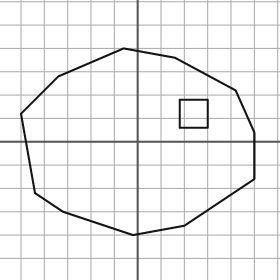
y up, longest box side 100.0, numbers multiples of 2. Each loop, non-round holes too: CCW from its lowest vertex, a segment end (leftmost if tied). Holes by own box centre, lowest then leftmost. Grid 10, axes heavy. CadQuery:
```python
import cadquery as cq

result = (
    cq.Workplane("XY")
    .moveTo(-2.0, -40.0)
    .lineTo(20.0, -36.0)
    .lineTo(50.0, -16.0)
    .lineTo(50.0, 4.0)
    .lineTo(42.0, 22.0)
    .lineTo(16.0, 36.0)
    .lineTo(-6.0, 40.0)
    .lineTo(-34.0, 28.0)
    .lineTo(-50.0, 12.0)
    .lineTo(-44.0, -22.0)
    .lineTo(-32.0, -30.0)
    .close()
    .moveTo(18.0, 6.0)
    .lineTo(30.0, 6.0)
    .lineTo(30.0, 18.0)
    .lineTo(18.0, 18.0)
    .close()
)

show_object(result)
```